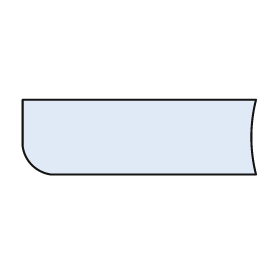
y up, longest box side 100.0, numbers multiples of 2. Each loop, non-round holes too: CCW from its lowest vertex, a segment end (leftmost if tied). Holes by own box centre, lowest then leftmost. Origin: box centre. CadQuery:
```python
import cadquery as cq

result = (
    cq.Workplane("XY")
    .moveTo(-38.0, -16.0)
    .lineTo(50.0, -16.0)
    .threePointArc((48.0, 0.0), (50.0, 16.0))
    .lineTo(-50.0, 16.0)
    .lineTo(-50.0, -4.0)
    .threePointArc((-46.0, -12.0), (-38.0, -16.0))
    .close()
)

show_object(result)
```